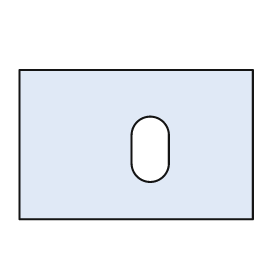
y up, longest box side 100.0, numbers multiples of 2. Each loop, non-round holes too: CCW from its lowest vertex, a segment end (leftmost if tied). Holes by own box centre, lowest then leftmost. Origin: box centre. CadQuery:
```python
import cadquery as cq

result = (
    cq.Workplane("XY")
    .moveTo(-50.0, -32.0)
    .lineTo(50.0, -32.0)
    .lineTo(50.0, 32.0)
    .lineTo(-50.0, 32.0)
    .close()
    .moveTo(-2.0, -8.0)
    .threePointArc((6.0, -16.0), (14.0, -8.0))
    .lineTo(14.0, 4.0)
    .threePointArc((6.0, 12.0), (-2.0, 4.0))
    .close()
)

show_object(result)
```